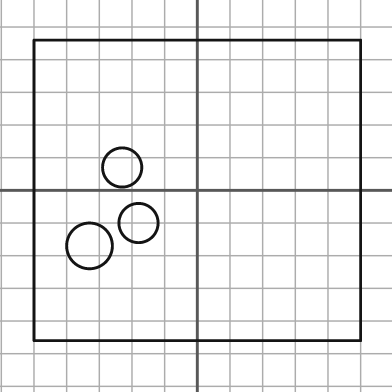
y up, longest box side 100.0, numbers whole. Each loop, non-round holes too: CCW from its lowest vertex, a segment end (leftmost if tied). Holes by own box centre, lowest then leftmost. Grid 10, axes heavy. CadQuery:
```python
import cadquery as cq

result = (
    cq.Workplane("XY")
    .moveTo(-50.0, -46.0)
    .lineTo(50.0, -46.0)
    .lineTo(50.0, 46.0)
    .lineTo(-50.0, 46.0)
    .close()
    .moveTo(-33.0, -17.0)
    .circle(7.0)
    .moveTo(-18.0, -10.0)
    .circle(6.0)
    .moveTo(-23.0, 7.0)
    .circle(6.0)
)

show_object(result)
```